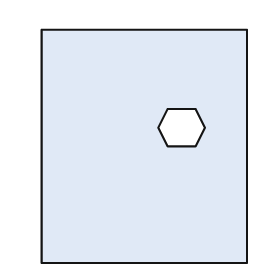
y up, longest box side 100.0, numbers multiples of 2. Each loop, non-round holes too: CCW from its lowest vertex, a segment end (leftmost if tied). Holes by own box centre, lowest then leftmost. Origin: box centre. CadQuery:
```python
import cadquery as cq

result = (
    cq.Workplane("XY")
    .moveTo(-44.0, -50.0)
    .lineTo(44.0, -50.0)
    .lineTo(44.0, 50.0)
    .lineTo(-44.0, 50.0)
    .close()
    .moveTo(10.0, 0.0)
    .lineTo(22.0, 0.0)
    .lineTo(26.0, 8.0)
    .lineTo(22.0, 16.0)
    .lineTo(10.0, 16.0)
    .lineTo(6.0, 8.0)
    .close()
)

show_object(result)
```